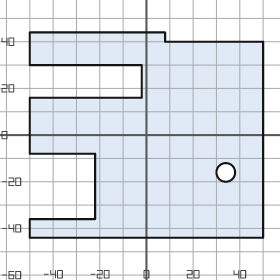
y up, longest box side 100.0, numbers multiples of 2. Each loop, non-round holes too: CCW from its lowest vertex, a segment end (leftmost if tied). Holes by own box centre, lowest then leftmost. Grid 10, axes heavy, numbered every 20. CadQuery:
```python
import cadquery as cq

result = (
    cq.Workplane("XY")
    .moveTo(-50.0, -44.0)
    .lineTo(50.0, -44.0)
    .lineTo(50.0, 40.0)
    .lineTo(8.0, 40.0)
    .lineTo(8.0, 44.0)
    .lineTo(-50.0, 44.0)
    .lineTo(-50.0, 30.0)
    .lineTo(-2.0, 30.0)
    .lineTo(-2.0, 16.0)
    .lineTo(-50.0, 16.0)
    .lineTo(-50.0, -8.0)
    .lineTo(-22.0, -8.0)
    .lineTo(-22.0, -36.0)
    .lineTo(-50.0, -36.0)
    .close()
    .moveTo(34.0, -16.0)
    .circle(4.0)
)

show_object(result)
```